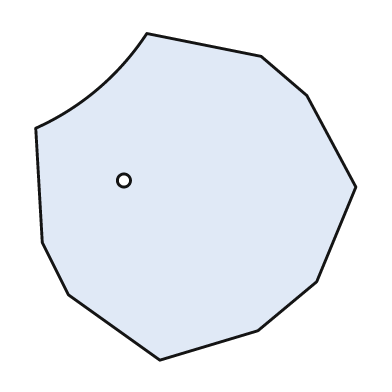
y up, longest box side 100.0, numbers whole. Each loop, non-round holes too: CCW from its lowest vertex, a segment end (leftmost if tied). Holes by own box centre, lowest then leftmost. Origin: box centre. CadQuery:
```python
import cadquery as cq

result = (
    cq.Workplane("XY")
    .moveTo(-11.0, -50.0)
    .lineTo(19.0, -41.0)
    .lineTo(37.0, -26.0)
    .lineTo(49.0, 3.0)
    .lineTo(34.0, 31.0)
    .lineTo(20.0, 43.0)
    .lineTo(-15.0, 50.0)
    .threePointArc((-30.0, 33.0), (-49.0, 21.0))
    .lineTo(-47.0, -14.0)
    .lineTo(-39.0, -30.0)
    .close()
    .moveTo(-22.0, 5.0)
    .circle(2.0)
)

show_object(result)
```